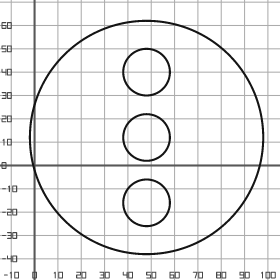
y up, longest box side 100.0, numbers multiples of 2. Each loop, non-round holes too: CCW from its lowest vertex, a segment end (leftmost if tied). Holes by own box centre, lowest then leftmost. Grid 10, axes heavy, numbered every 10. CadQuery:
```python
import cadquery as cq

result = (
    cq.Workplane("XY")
    .moveTo(48.0, 12.0)
    .circle(50.0)
    .moveTo(48.0, -16.0)
    .circle(10.0)
    .moveTo(48.0, 12.0)
    .circle(10.0)
    .moveTo(48.0, 40.0)
    .circle(10.0)
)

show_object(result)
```